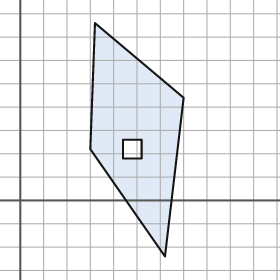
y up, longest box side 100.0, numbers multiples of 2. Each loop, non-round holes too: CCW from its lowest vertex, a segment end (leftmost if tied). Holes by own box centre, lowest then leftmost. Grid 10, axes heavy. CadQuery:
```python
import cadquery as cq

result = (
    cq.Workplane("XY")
    .moveTo(62.0, -24.0)
    .lineTo(70.0, 44.0)
    .lineTo(32.0, 76.0)
    .lineTo(30.0, 22.0)
    .close()
    .moveTo(44.0, 18.0)
    .lineTo(52.0, 18.0)
    .lineTo(52.0, 26.0)
    .lineTo(44.0, 26.0)
    .close()
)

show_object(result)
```